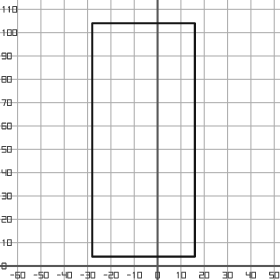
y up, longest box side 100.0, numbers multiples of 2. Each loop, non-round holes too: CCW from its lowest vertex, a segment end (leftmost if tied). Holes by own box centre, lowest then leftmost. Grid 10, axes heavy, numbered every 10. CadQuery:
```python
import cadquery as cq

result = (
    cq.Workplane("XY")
    .moveTo(-28.0, 4.0)
    .lineTo(16.0, 4.0)
    .lineTo(16.0, 104.0)
    .lineTo(-28.0, 104.0)
    .close()
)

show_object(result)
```